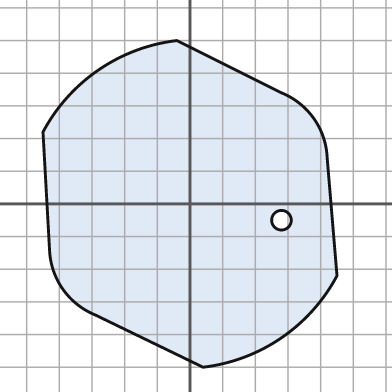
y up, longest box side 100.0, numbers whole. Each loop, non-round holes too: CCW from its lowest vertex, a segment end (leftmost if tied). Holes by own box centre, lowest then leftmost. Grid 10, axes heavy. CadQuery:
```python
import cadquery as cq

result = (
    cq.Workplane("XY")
    .moveTo(4.0, -50.0)
    .threePointArc((28.0, -41.0), (45.0, -22.0))
    .lineTo(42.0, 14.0)
    .threePointArc((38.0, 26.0), (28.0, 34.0))
    .lineTo(-4.0, 50.0)
    .threePointArc((-28.0, 41.0), (-45.0, 22.0))
    .lineTo(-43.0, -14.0)
    .threePointArc((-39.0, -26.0), (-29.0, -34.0))
    .close()
    .moveTo(28.0, -5.0)
    .circle(3.0)
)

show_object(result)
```